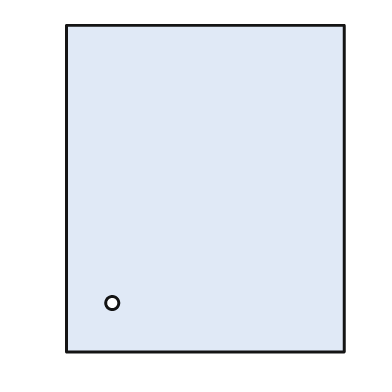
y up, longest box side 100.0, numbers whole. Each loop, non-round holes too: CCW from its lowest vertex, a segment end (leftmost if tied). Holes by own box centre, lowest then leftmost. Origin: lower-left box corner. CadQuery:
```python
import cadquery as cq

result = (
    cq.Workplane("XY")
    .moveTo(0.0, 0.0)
    .lineTo(85.0, 0.0)
    .lineTo(85.0, 100.0)
    .lineTo(0.0, 100.0)
    .close()
    .moveTo(14.0, 15.0)
    .circle(2.0)
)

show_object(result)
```